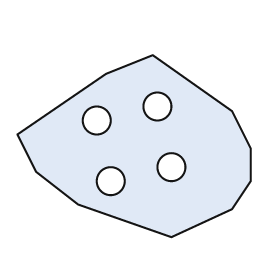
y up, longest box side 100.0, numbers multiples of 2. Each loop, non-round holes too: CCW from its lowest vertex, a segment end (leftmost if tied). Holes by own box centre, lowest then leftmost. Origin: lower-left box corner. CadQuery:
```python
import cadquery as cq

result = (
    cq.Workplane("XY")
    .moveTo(66.0, 0.0)
    .lineTo(92.0, 12.0)
    .lineTo(100.0, 24.0)
    .lineTo(100.0, 38.0)
    .lineTo(92.0, 54.0)
    .lineTo(58.0, 78.0)
    .lineTo(38.0, 70.0)
    .lineTo(0.0, 44.0)
    .lineTo(8.0, 28.0)
    .lineTo(26.0, 14.0)
    .close()
    .moveTo(40.0, 24.0)
    .circle(6.0)
    .moveTo(66.0, 30.0)
    .circle(6.0)
    .moveTo(34.0, 50.0)
    .circle(6.0)
    .moveTo(60.0, 56.0)
    .circle(6.0)
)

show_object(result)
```